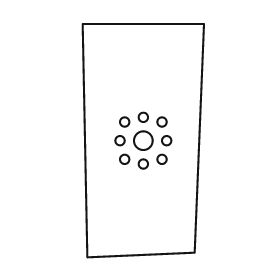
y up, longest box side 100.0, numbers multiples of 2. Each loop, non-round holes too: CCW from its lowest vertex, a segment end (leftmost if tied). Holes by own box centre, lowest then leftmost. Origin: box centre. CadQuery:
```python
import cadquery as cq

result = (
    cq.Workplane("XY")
    .moveTo(-24.0, -50.0)
    .lineTo(22.0, -48.0)
    .lineTo(26.0, 50.0)
    .lineTo(-26.0, 50.0)
    .close()
    .moveTo(0.0, -10.0)
    .circle(2.0)
    .moveTo(-8.0, -8.0)
    .circle(2.0)
    .moveTo(8.0, -8.0)
    .circle(2.0)
    .moveTo(-10.0, 0.0)
    .circle(2.0)
    .moveTo(0.0, 0.0)
    .circle(4.0)
    .moveTo(10.0, 0.0)
    .circle(2.0)
    .moveTo(-8.0, 8.0)
    .circle(2.0)
    .moveTo(8.0, 8.0)
    .circle(2.0)
    .moveTo(0.0, 10.0)
    .circle(2.0)
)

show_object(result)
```